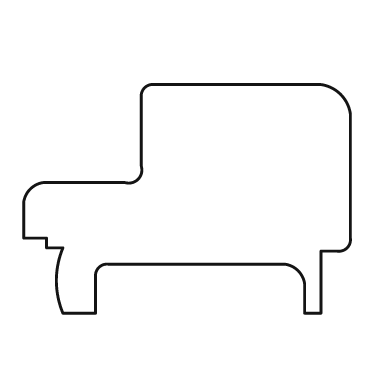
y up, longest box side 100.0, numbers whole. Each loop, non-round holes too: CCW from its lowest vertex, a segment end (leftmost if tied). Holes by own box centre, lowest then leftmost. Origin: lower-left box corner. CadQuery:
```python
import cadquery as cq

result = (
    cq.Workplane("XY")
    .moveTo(12.0, 0.0)
    .lineTo(22.0, 0.0)
    .lineTo(22.0, 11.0)
    .threePointArc((23.0, 14.0), (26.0, 15.0))
    .lineTo(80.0, 15.0)
    .threePointArc((84.0, 13.0), (86.0, 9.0))
    .lineTo(86.0, 0.0)
    .lineTo(91.0, 0.0)
    .lineTo(91.0, 19.0)
    .lineTo(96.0, 19.0)
    .threePointArc((99.0, 20.0), (100.0, 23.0))
    .lineTo(100.0, 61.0)
    .threePointArc((97.0, 67.0), (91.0, 70.0))
    .lineTo(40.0, 70.0)
    .threePointArc((37.0, 69.0), (36.0, 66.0))
    .lineTo(36.0, 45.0)
    .threePointArc((35.0, 41.0), (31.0, 40.0))
    .lineTo(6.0, 40.0)
    .threePointArc((2.0, 38.0), (0.0, 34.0))
    .lineTo(0.0, 23.0)
    .lineTo(7.0, 23.0)
    .lineTo(7.0, 20.0)
    .lineTo(12.0, 20.0)
    .threePointArc((10.0, 10.0), (12.0, 0.0))
    .close()
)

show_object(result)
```